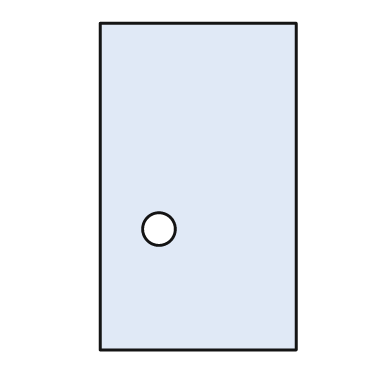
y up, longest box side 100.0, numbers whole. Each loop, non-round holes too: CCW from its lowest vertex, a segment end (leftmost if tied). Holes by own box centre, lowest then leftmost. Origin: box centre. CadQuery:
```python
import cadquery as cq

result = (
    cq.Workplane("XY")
    .moveTo(-30.0, -50.0)
    .lineTo(30.0, -50.0)
    .lineTo(30.0, 50.0)
    .lineTo(-30.0, 50.0)
    .close()
    .moveTo(-12.0, -13.0)
    .circle(5.0)
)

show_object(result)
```